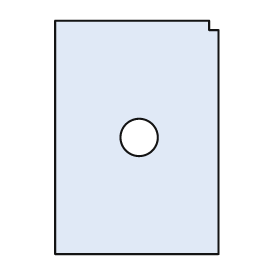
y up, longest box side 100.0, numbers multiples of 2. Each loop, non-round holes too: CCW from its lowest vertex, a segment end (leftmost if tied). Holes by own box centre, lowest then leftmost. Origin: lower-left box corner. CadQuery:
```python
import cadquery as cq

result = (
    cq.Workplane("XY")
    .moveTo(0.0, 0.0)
    .lineTo(70.0, 0.0)
    .lineTo(70.0, 96.0)
    .lineTo(66.0, 96.0)
    .lineTo(66.0, 100.0)
    .lineTo(0.0, 100.0)
    .close()
    .moveTo(36.0, 50.0)
    .circle(8.0)
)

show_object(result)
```